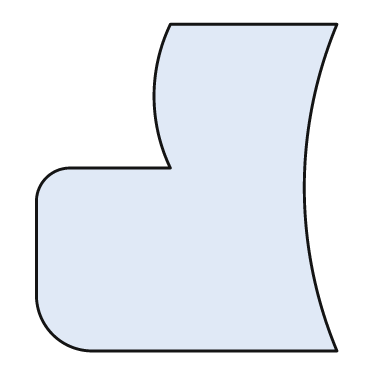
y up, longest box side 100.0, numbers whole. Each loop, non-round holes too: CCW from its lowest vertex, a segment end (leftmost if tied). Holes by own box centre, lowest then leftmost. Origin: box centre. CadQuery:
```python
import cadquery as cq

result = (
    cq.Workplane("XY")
    .moveTo(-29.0, -50.0)
    .lineTo(46.0, -50.0)
    .threePointArc((36.0, 0.0), (46.0, 50.0))
    .lineTo(-5.0, 50.0)
    .threePointArc((-10.0, 28.0), (-5.0, 6.0))
    .lineTo(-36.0, 6.0)
    .threePointArc((-43.0, 3.0), (-46.0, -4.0))
    .lineTo(-46.0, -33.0)
    .threePointArc((-41.0, -45.0), (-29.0, -50.0))
    .close()
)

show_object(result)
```